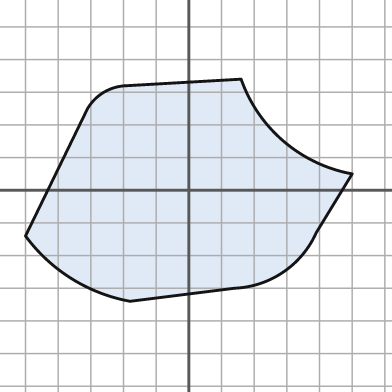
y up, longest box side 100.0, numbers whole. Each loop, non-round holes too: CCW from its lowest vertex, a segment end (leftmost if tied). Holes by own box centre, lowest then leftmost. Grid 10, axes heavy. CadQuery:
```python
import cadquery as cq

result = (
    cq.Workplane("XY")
    .moveTo(-18.0, -34.0)
    .lineTo(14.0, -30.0)
    .threePointArc((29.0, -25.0), (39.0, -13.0))
    .lineTo(50.0, 5.0)
    .threePointArc((29.0, 15.0), (16.0, 34.0))
    .lineTo(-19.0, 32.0)
    .threePointArc((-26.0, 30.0), (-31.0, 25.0))
    .lineTo(-50.0, -14.0)
    .threePointArc((-36.0, -27.0), (-18.0, -34.0))
    .close()
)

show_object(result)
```